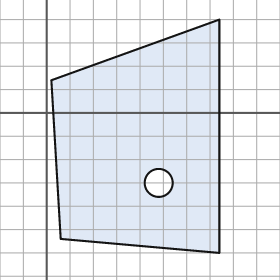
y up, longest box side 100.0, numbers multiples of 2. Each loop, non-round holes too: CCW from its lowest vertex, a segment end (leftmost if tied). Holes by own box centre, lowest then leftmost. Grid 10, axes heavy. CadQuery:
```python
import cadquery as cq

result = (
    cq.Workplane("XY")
    .moveTo(74.0, -60.0)
    .lineTo(74.0, 40.0)
    .lineTo(2.0, 14.0)
    .lineTo(6.0, -54.0)
    .close()
    .moveTo(48.0, -30.0)
    .circle(6.0)
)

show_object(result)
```